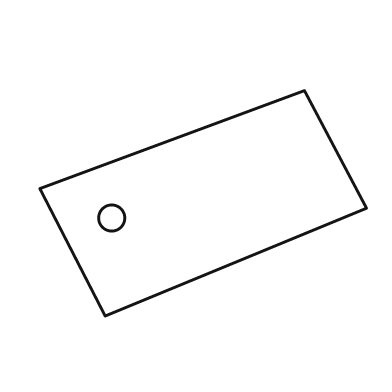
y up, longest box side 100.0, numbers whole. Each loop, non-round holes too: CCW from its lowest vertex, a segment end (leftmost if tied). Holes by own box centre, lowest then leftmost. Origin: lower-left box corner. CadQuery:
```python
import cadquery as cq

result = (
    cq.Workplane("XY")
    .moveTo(20.0, 0.0)
    .lineTo(100.0, 33.0)
    .lineTo(81.0, 69.0)
    .lineTo(0.0, 39.0)
    .close()
    .moveTo(22.0, 30.0)
    .circle(4.0)
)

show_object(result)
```